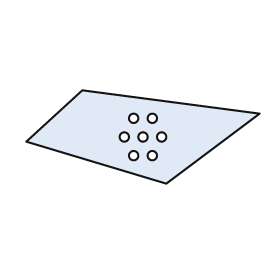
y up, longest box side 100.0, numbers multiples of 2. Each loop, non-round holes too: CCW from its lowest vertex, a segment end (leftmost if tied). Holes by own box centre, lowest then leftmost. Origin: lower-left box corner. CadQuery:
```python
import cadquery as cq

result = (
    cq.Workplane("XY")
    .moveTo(60.0, 0.0)
    .lineTo(100.0, 30.0)
    .lineTo(24.0, 40.0)
    .lineTo(0.0, 18.0)
    .close()
    .moveTo(46.0, 12.0)
    .circle(2.0)
    .moveTo(54.0, 12.0)
    .circle(2.0)
    .moveTo(42.0, 20.0)
    .circle(2.0)
    .moveTo(50.0, 20.0)
    .circle(2.0)
    .moveTo(58.0, 20.0)
    .circle(2.0)
    .moveTo(46.0, 28.0)
    .circle(2.0)
    .moveTo(54.0, 28.0)
    .circle(2.0)
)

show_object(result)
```